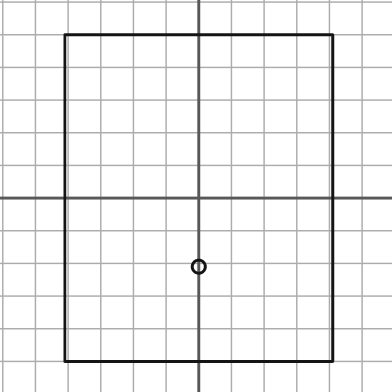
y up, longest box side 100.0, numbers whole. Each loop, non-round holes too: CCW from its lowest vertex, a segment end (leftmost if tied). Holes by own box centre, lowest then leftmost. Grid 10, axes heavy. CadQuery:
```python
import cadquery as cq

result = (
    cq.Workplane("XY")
    .moveTo(-41.0, -50.0)
    .lineTo(41.0, -50.0)
    .lineTo(41.0, 50.0)
    .lineTo(-41.0, 50.0)
    .close()
    .moveTo(0.0, -21.0)
    .circle(2.0)
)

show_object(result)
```